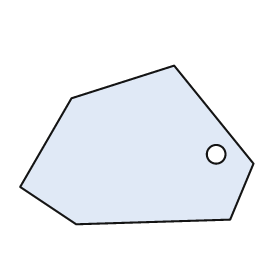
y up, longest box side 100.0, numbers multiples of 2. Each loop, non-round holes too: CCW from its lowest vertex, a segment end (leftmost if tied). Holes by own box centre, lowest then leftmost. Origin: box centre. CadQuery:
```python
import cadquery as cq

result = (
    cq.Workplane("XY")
    .moveTo(-26.0, -34.0)
    .lineTo(40.0, -32.0)
    .lineTo(50.0, -8.0)
    .lineTo(16.0, 34.0)
    .lineTo(-28.0, 20.0)
    .lineTo(-50.0, -18.0)
    .close()
    .moveTo(34.0, -4.0)
    .circle(4.0)
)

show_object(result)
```